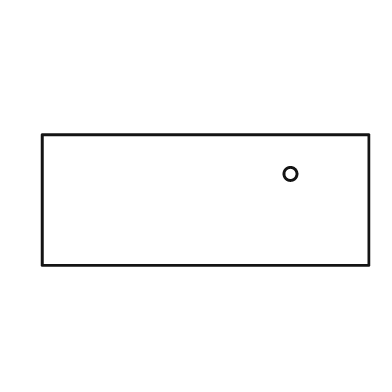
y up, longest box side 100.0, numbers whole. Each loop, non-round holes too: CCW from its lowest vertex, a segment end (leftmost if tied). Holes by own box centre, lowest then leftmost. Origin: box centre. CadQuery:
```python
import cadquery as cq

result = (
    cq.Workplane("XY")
    .moveTo(-50.0, -20.0)
    .lineTo(50.0, -20.0)
    .lineTo(50.0, 20.0)
    .lineTo(-50.0, 20.0)
    .close()
    .moveTo(26.0, 8.0)
    .circle(2.0)
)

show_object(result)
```